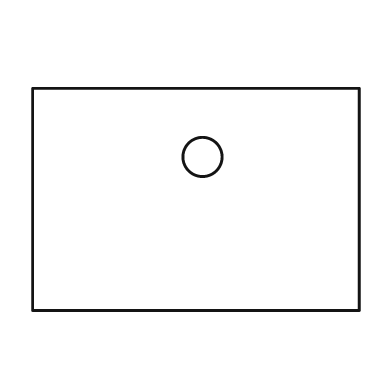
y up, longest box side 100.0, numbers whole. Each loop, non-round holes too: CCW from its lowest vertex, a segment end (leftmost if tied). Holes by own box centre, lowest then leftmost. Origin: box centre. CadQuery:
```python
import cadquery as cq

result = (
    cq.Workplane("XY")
    .moveTo(-50.0, -34.0)
    .lineTo(50.0, -34.0)
    .lineTo(50.0, 34.0)
    .lineTo(-50.0, 34.0)
    .close()
    .moveTo(2.0, 13.0)
    .circle(6.0)
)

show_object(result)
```